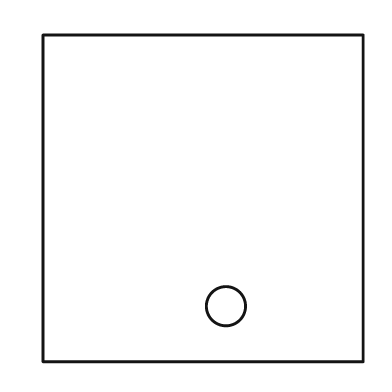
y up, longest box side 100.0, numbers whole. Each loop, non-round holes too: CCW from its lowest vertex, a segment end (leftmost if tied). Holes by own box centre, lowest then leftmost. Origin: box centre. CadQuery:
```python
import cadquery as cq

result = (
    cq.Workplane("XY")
    .moveTo(-49.0, -50.0)
    .lineTo(49.0, -50.0)
    .lineTo(49.0, 50.0)
    .lineTo(-49.0, 50.0)
    .close()
    .moveTo(7.0, -33.0)
    .circle(6.0)
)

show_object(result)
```